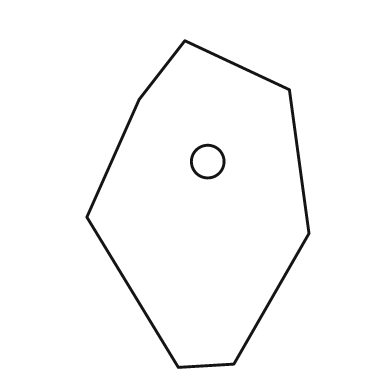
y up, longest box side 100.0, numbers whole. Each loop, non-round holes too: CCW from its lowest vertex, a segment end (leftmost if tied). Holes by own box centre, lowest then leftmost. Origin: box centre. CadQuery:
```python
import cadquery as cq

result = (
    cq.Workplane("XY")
    .moveTo(-6.0, -50.0)
    .lineTo(11.0, -49.0)
    .lineTo(34.0, -9.0)
    .lineTo(28.0, 35.0)
    .lineTo(-4.0, 50.0)
    .lineTo(-18.0, 32.0)
    .lineTo(-34.0, -4.0)
    .close()
    .moveTo(3.0, 13.0)
    .circle(5.0)
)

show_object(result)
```